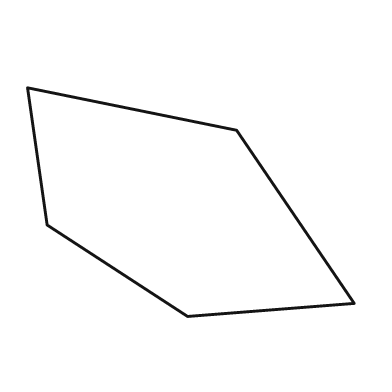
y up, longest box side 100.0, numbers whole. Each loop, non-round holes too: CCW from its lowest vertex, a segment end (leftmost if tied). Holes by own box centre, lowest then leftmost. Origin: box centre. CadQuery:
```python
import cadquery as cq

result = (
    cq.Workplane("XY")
    .moveTo(-1.0, -35.0)
    .lineTo(50.0, -31.0)
    .lineTo(14.0, 22.0)
    .lineTo(-50.0, 35.0)
    .lineTo(-44.0, -7.0)
    .close()
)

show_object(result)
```